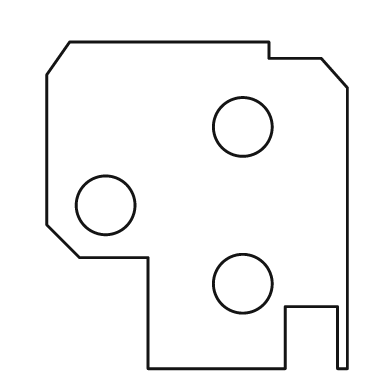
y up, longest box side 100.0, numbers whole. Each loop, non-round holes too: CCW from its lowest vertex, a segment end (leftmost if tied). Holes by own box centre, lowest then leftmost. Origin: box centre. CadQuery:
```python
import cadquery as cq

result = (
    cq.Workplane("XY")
    .moveTo(-15.0, -50.0)
    .lineTo(27.0, -50.0)
    .lineTo(27.0, -31.0)
    .lineTo(43.0, -31.0)
    .lineTo(43.0, -50.0)
    .lineTo(46.0, -50.0)
    .lineTo(46.0, 36.0)
    .lineTo(38.0, 45.0)
    .lineTo(22.0, 45.0)
    .lineTo(22.0, 50.0)
    .lineTo(-39.0, 50.0)
    .lineTo(-46.0, 40.0)
    .lineTo(-46.0, -6.0)
    .lineTo(-36.0, -16.0)
    .lineTo(-15.0, -16.0)
    .close()
    .moveTo(14.0, -24.0)
    .circle(9.0)
    .moveTo(-28.0, 0.0)
    .circle(9.0)
    .moveTo(14.0, 24.0)
    .circle(9.0)
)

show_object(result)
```